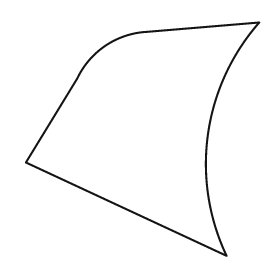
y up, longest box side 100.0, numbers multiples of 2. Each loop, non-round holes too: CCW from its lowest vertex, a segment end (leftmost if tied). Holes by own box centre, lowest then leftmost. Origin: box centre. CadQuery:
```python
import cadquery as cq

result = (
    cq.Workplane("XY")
    .moveTo(36.0, -50.0)
    .threePointArc((28.0, 2.0), (50.0, 50.0))
    .lineTo(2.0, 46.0)
    .threePointArc((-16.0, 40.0), (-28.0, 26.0))
    .lineTo(-50.0, -10.0)
    .close()
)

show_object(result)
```